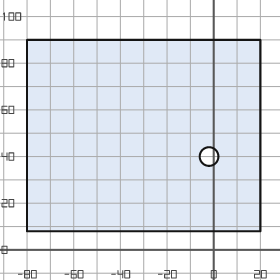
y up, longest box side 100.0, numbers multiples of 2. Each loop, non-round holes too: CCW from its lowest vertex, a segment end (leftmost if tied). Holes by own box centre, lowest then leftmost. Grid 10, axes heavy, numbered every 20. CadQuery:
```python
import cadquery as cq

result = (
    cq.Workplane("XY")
    .moveTo(-80.0, 8.0)
    .lineTo(20.0, 8.0)
    .lineTo(20.0, 90.0)
    .lineTo(-80.0, 90.0)
    .close()
    .moveTo(-2.0, 40.0)
    .circle(4.0)
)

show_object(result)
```